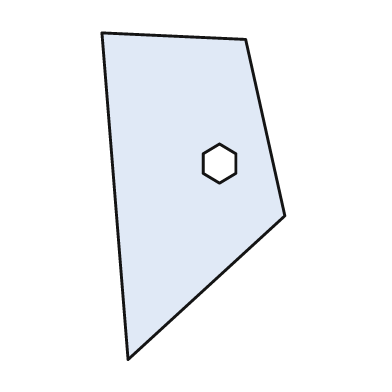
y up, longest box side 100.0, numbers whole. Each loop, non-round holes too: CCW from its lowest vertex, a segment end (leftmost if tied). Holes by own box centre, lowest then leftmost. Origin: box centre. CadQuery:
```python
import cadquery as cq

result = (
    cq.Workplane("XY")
    .moveTo(-20.0, -50.0)
    .lineTo(28.0, -6.0)
    .lineTo(16.0, 48.0)
    .lineTo(-28.0, 50.0)
    .close()
    .moveTo(8.0, 4.0)
    .lineTo(13.0, 7.0)
    .lineTo(13.0, 13.0)
    .lineTo(8.0, 16.0)
    .lineTo(3.0, 13.0)
    .lineTo(3.0, 7.0)
    .close()
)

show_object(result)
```